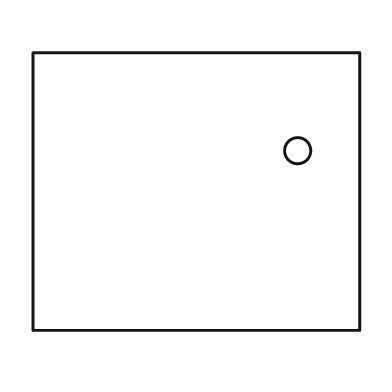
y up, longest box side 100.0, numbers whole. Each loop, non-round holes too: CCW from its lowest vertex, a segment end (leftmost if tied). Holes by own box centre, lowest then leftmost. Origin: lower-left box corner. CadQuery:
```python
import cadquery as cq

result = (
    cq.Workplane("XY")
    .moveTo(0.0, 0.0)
    .lineTo(100.0, 0.0)
    .lineTo(100.0, 85.0)
    .lineTo(0.0, 85.0)
    .close()
    .moveTo(81.0, 55.0)
    .circle(4.0)
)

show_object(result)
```